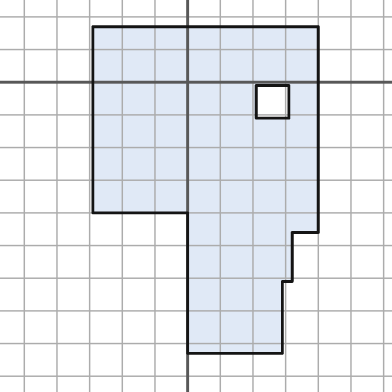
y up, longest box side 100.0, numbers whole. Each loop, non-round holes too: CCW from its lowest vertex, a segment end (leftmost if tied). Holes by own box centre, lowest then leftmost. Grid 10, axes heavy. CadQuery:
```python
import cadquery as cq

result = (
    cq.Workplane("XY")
    .moveTo(0.0, -83.0)
    .lineTo(29.0, -83.0)
    .lineTo(29.0, -61.0)
    .lineTo(32.0, -61.0)
    .lineTo(32.0, -46.0)
    .lineTo(40.0, -46.0)
    .lineTo(40.0, 17.0)
    .lineTo(-29.0, 17.0)
    .lineTo(-29.0, -40.0)
    .lineTo(0.0, -40.0)
    .close()
    .moveTo(21.0, -11.0)
    .lineTo(31.0, -11.0)
    .lineTo(31.0, -1.0)
    .lineTo(21.0, -1.0)
    .close()
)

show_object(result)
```